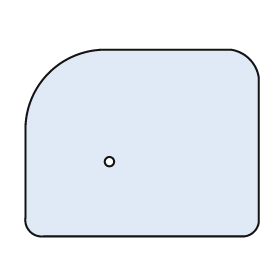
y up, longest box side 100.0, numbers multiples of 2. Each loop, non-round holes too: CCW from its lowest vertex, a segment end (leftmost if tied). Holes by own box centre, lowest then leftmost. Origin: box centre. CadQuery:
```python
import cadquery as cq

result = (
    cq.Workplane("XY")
    .moveTo(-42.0, -40.0)
    .lineTo(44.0, -40.0)
    .threePointArc((48.0, -38.0), (50.0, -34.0))
    .lineTo(50.0, 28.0)
    .threePointArc((46.0, 36.0), (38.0, 40.0))
    .lineTo(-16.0, 40.0)
    .threePointArc((-40.0, 30.0), (-50.0, 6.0))
    .lineTo(-50.0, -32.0)
    .threePointArc((-48.0, -38.0), (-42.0, -40.0))
    .close()
    .moveTo(-14.0, -8.0)
    .circle(2.0)
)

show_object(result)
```